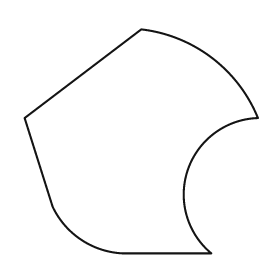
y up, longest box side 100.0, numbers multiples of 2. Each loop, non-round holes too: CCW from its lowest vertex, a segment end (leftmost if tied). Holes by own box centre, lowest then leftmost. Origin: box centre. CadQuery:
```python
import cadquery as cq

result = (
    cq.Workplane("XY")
    .moveTo(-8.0, -48.0)
    .lineTo(30.0, -48.0)
    .threePointArc((20.0, -12.0), (50.0, 10.0))
    .threePointArc((30.0, 36.0), (0.0, 48.0))
    .lineTo(-50.0, 10.0)
    .lineTo(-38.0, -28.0)
    .threePointArc((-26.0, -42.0), (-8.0, -48.0))
    .close()
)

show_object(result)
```